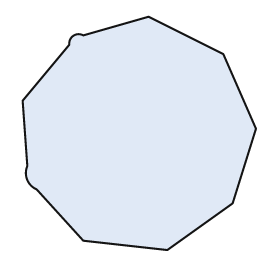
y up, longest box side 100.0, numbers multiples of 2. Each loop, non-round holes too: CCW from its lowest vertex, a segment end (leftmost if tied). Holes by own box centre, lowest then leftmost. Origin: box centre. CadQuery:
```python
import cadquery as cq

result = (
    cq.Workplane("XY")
    .moveTo(12.0, -50.0)
    .lineTo(40.0, -30.0)
    .lineTo(50.0, 2.0)
    .lineTo(36.0, 34.0)
    .lineTo(4.0, 50.0)
    .lineTo(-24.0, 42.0)
    .threePointArc((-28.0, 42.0), (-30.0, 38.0))
    .lineTo(-50.0, 14.0)
    .lineTo(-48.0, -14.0)
    .threePointArc((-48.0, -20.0), (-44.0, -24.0))
    .lineTo(-24.0, -46.0)
    .close()
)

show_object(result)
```